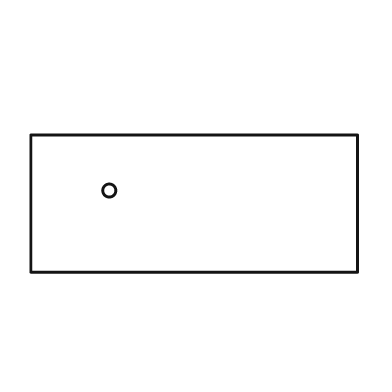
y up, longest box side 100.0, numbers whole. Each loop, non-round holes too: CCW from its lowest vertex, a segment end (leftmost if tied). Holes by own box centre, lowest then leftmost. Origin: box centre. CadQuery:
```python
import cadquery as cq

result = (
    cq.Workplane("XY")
    .moveTo(-50.0, -21.0)
    .lineTo(50.0, -21.0)
    .lineTo(50.0, 21.0)
    .lineTo(-50.0, 21.0)
    .close()
    .moveTo(-26.0, 4.0)
    .circle(2.0)
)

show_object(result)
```